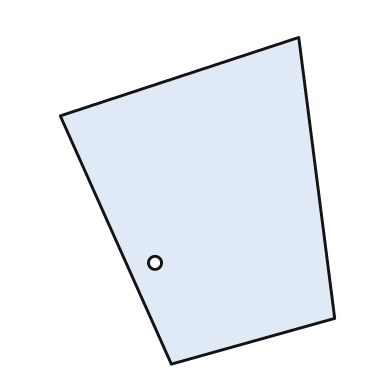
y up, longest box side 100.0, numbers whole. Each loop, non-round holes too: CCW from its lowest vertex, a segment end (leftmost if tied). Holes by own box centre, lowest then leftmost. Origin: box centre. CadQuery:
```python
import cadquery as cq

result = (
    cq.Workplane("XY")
    .moveTo(-8.0, -50.0)
    .lineTo(42.0, -36.0)
    .lineTo(31.0, 50.0)
    .lineTo(-42.0, 26.0)
    .close()
    .moveTo(-13.0, -19.0)
    .circle(2.0)
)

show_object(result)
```